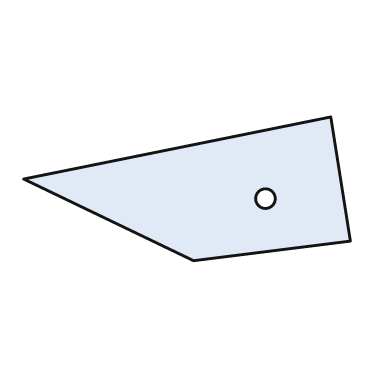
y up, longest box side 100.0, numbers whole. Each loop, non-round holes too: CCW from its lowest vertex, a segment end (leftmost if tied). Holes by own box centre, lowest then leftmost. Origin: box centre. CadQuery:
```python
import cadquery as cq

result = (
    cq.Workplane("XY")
    .moveTo(2.0, -22.0)
    .lineTo(50.0, -16.0)
    .lineTo(44.0, 22.0)
    .lineTo(-50.0, 3.0)
    .close()
    .moveTo(24.0, -3.0)
    .circle(3.0)
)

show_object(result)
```